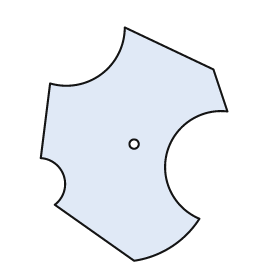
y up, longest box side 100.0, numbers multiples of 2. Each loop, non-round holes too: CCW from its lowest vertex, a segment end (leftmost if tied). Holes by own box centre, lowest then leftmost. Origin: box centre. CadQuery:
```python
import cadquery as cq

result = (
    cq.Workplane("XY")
    .moveTo(0.0, -50.0)
    .threePointArc((16.0, -44.0), (28.0, -32.0))
    .threePointArc((14.0, -4.0), (40.0, 14.0))
    .lineTo(34.0, 32.0)
    .lineTo(-4.0, 50.0)
    .threePointArc((-14.0, 30.0), (-36.0, 26.0))
    .lineTo(-40.0, -6.0)
    .threePointArc((-30.0, -14.0), (-34.0, -26.0))
    .close()
    .moveTo(0.0, 0.0)
    .circle(2.0)
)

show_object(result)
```